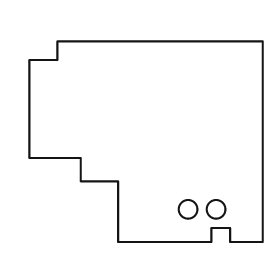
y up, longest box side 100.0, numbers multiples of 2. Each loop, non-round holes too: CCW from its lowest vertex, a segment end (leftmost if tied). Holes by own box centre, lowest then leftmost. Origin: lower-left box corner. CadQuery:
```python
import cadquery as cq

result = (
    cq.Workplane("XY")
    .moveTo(38.0, 0.0)
    .lineTo(78.0, 0.0)
    .lineTo(78.0, 6.0)
    .lineTo(86.0, 6.0)
    .lineTo(86.0, 0.0)
    .lineTo(100.0, 0.0)
    .lineTo(100.0, 86.0)
    .lineTo(12.0, 86.0)
    .lineTo(12.0, 78.0)
    .lineTo(0.0, 78.0)
    .lineTo(0.0, 36.0)
    .lineTo(22.0, 36.0)
    .lineTo(22.0, 26.0)
    .lineTo(38.0, 26.0)
    .close()
    .moveTo(68.0, 14.0)
    .circle(4.0)
    .moveTo(80.0, 14.0)
    .circle(4.0)
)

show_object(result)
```